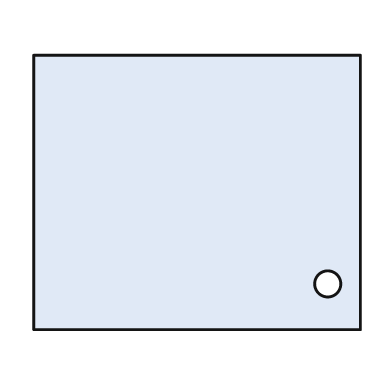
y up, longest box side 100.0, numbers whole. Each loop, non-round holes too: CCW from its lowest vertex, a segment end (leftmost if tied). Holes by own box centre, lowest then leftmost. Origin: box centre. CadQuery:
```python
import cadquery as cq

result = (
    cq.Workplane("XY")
    .moveTo(-50.0, -42.0)
    .lineTo(50.0, -42.0)
    .lineTo(50.0, 42.0)
    .lineTo(-50.0, 42.0)
    .close()
    .moveTo(40.0, -28.0)
    .circle(4.0)
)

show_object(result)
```